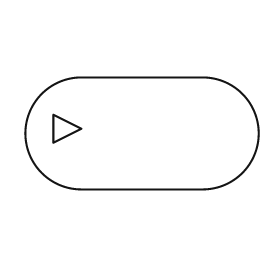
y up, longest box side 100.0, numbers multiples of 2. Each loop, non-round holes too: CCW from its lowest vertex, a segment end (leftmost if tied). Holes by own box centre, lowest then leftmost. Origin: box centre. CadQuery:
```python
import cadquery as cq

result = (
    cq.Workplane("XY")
    .moveTo(-26.0, -24.0)
    .lineTo(26.0, -24.0)
    .threePointArc((50.0, 0.0), (26.0, 24.0))
    .lineTo(-26.0, 24.0)
    .threePointArc((-50.0, 0.0), (-26.0, -24.0))
    .close()
    .moveTo(-38.0, -4.0)
    .lineTo(-26.0, 2.0)
    .lineTo(-38.0, 8.0)
    .close()
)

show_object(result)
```